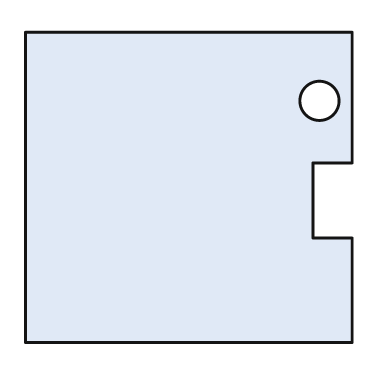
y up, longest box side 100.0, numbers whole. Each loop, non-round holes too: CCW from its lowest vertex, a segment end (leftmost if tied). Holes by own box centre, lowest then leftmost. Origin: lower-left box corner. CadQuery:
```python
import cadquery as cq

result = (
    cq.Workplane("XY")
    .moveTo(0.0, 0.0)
    .lineTo(100.0, 0.0)
    .lineTo(100.0, 32.0)
    .lineTo(88.0, 32.0)
    .lineTo(88.0, 55.0)
    .lineTo(100.0, 55.0)
    .lineTo(100.0, 95.0)
    .lineTo(0.0, 95.0)
    .close()
    .moveTo(90.0, 74.0)
    .circle(6.0)
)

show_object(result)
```